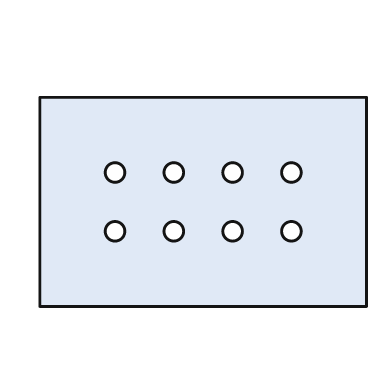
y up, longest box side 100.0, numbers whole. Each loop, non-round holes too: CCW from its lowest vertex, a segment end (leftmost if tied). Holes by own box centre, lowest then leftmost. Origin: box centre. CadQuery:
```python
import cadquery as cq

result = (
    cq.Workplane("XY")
    .moveTo(-50.0, -32.0)
    .lineTo(50.0, -32.0)
    .lineTo(50.0, 32.0)
    .lineTo(-50.0, 32.0)
    .close()
    .moveTo(-27.0, -9.0)
    .circle(3.0)
    .moveTo(-9.0, -9.0)
    .circle(3.0)
    .moveTo(9.0, -9.0)
    .circle(3.0)
    .moveTo(27.0, -9.0)
    .circle(3.0)
    .moveTo(-27.0, 9.0)
    .circle(3.0)
    .moveTo(-9.0, 9.0)
    .circle(3.0)
    .moveTo(9.0, 9.0)
    .circle(3.0)
    .moveTo(27.0, 9.0)
    .circle(3.0)
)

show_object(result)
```